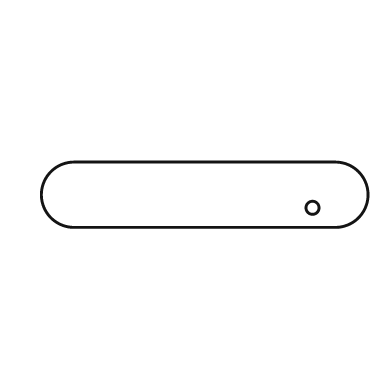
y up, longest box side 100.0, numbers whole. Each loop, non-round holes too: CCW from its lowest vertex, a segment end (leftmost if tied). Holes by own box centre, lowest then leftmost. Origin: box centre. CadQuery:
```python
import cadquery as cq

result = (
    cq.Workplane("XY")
    .moveTo(-40.0, -10.0)
    .lineTo(40.0, -10.0)
    .threePointArc((50.0, 0.0), (40.0, 10.0))
    .lineTo(-40.0, 10.0)
    .threePointArc((-50.0, 0.0), (-40.0, -10.0))
    .close()
    .moveTo(33.0, -4.0)
    .circle(2.0)
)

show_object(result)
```